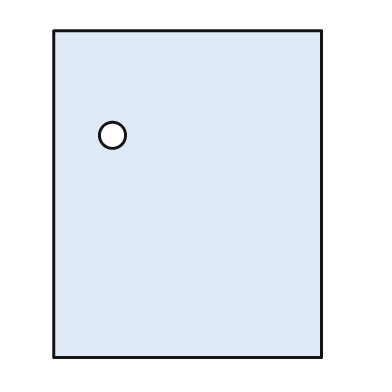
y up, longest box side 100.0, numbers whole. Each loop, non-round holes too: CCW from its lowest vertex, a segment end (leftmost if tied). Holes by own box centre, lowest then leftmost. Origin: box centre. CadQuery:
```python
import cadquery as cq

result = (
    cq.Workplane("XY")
    .moveTo(-41.0, -50.0)
    .lineTo(41.0, -50.0)
    .lineTo(41.0, 50.0)
    .lineTo(-41.0, 50.0)
    .close()
    .moveTo(-23.0, 18.0)
    .circle(4.0)
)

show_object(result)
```